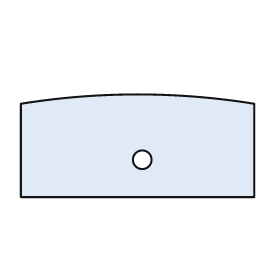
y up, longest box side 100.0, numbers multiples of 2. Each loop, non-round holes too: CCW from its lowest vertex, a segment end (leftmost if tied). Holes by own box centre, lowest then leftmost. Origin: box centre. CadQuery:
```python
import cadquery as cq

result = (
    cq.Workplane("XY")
    .moveTo(-50.0, -22.0)
    .lineTo(50.0, -22.0)
    .lineTo(50.0, 18.0)
    .threePointArc((0.0, 22.0), (-50.0, 18.0))
    .close()
    .moveTo(2.0, -6.0)
    .circle(4.0)
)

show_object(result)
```